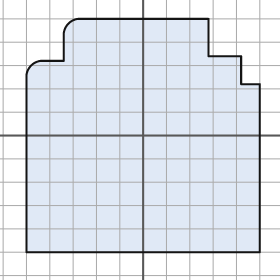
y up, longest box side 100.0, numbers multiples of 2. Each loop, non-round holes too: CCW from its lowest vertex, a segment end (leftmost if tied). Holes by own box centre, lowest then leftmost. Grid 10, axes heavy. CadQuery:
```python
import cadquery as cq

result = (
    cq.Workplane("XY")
    .moveTo(-50.0, -50.0)
    .lineTo(50.0, -50.0)
    .lineTo(50.0, 22.0)
    .lineTo(42.0, 22.0)
    .lineTo(42.0, 34.0)
    .lineTo(28.0, 34.0)
    .lineTo(28.0, 50.0)
    .lineTo(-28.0, 50.0)
    .threePointArc((-32.0, 48.0), (-34.0, 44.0))
    .lineTo(-34.0, 32.0)
    .lineTo(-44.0, 32.0)
    .threePointArc((-48.0, 30.0), (-50.0, 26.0))
    .close()
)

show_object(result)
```